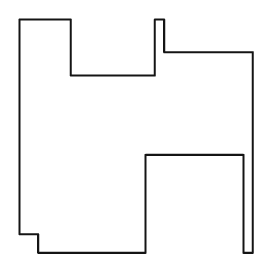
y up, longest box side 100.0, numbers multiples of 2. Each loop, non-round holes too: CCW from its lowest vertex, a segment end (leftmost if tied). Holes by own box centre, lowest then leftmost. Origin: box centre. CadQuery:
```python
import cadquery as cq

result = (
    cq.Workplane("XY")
    .moveTo(-42.0, -50.0)
    .lineTo(4.0, -50.0)
    .lineTo(4.0, -8.0)
    .lineTo(46.0, -8.0)
    .lineTo(46.0, -50.0)
    .lineTo(50.0, -50.0)
    .lineTo(50.0, 36.0)
    .lineTo(12.0, 36.0)
    .lineTo(12.0, 50.0)
    .lineTo(8.0, 50.0)
    .lineTo(8.0, 26.0)
    .lineTo(-28.0, 26.0)
    .lineTo(-28.0, 50.0)
    .lineTo(-50.0, 50.0)
    .lineTo(-50.0, -42.0)
    .lineTo(-42.0, -42.0)
    .close()
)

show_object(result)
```